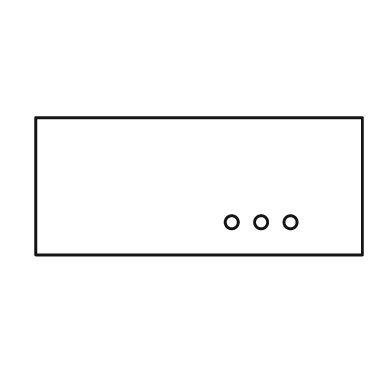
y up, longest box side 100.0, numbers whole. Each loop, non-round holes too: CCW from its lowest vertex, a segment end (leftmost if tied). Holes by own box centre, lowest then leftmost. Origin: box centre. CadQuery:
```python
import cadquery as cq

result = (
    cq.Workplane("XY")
    .moveTo(-50.0, -21.0)
    .lineTo(50.0, -21.0)
    .lineTo(50.0, 21.0)
    .lineTo(-50.0, 21.0)
    .close()
    .moveTo(10.0, -11.0)
    .circle(2.0)
    .moveTo(19.0, -11.0)
    .circle(2.0)
    .moveTo(28.0, -11.0)
    .circle(2.0)
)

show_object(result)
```